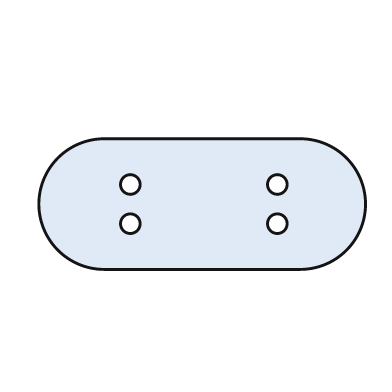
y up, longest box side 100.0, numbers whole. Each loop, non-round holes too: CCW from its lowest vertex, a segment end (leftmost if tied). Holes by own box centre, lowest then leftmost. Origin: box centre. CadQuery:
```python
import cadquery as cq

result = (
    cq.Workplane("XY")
    .moveTo(-30.0, -20.0)
    .lineTo(30.0, -20.0)
    .threePointArc((50.0, 0.0), (30.0, 20.0))
    .lineTo(-30.0, 20.0)
    .threePointArc((-50.0, 0.0), (-30.0, -20.0))
    .close()
    .moveTo(-22.0, -6.0)
    .circle(3.0)
    .moveTo(23.0, -6.0)
    .circle(3.0)
    .moveTo(-22.0, 6.0)
    .circle(3.0)
    .moveTo(23.0, 6.0)
    .circle(3.0)
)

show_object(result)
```